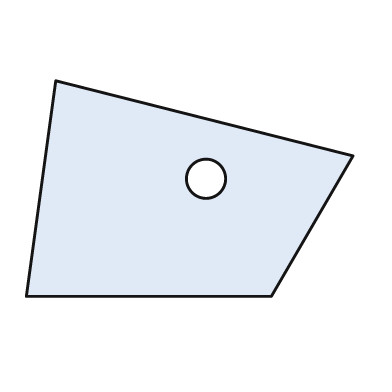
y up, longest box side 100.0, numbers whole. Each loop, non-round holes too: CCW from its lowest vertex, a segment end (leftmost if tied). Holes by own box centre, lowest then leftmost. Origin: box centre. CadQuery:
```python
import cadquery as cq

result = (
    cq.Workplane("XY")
    .moveTo(-50.0, -33.0)
    .lineTo(25.0, -33.0)
    .lineTo(50.0, 10.0)
    .lineTo(-41.0, 33.0)
    .close()
    .moveTo(5.0, 3.0)
    .circle(6.0)
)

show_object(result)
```